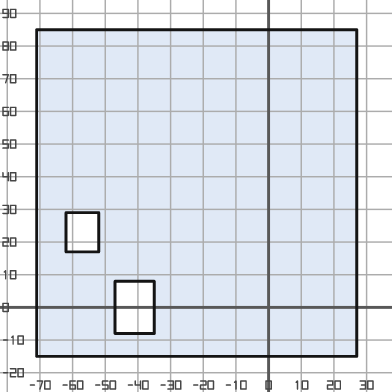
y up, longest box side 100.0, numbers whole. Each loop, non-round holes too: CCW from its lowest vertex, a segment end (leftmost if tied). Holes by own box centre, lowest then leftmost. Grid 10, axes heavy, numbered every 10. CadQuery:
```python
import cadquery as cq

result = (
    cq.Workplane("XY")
    .moveTo(-71.0, -15.0)
    .lineTo(27.0, -15.0)
    .lineTo(27.0, 85.0)
    .lineTo(-71.0, 85.0)
    .close()
    .moveTo(-47.0, -8.0)
    .lineTo(-35.0, -8.0)
    .lineTo(-35.0, 8.0)
    .lineTo(-47.0, 8.0)
    .close()
    .moveTo(-62.0, 17.0)
    .lineTo(-52.0, 17.0)
    .lineTo(-52.0, 29.0)
    .lineTo(-62.0, 29.0)
    .close()
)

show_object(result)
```